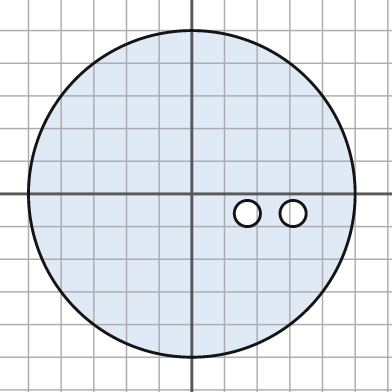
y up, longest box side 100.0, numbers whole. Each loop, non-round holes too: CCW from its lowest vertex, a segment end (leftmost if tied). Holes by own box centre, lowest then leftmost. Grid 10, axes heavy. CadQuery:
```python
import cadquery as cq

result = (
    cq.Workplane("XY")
    .moveTo(0.0, 0.0)
    .circle(50.0)
    .moveTo(17.0, -6.0)
    .circle(4.0)
    .moveTo(31.0, -6.0)
    .circle(4.0)
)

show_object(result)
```